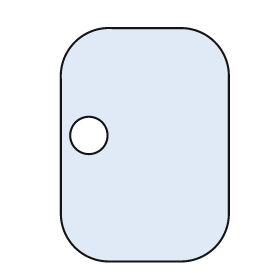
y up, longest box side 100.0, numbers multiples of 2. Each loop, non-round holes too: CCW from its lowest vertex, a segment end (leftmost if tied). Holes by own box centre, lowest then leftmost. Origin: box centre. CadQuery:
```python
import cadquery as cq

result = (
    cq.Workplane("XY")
    .moveTo(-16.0, -50.0)
    .lineTo(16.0, -50.0)
    .threePointArc((30.0, -44.0), (36.0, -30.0))
    .lineTo(36.0, 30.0)
    .threePointArc((30.0, 44.0), (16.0, 50.0))
    .lineTo(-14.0, 50.0)
    .threePointArc((-30.0, 44.0), (-36.0, 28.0))
    .lineTo(-36.0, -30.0)
    .threePointArc((-30.0, -44.0), (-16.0, -50.0))
    .close()
    .moveTo(-24.0, 4.0)
    .circle(8.0)
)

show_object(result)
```